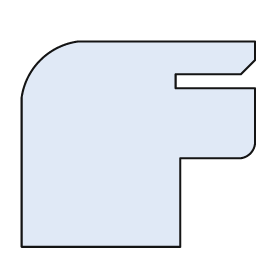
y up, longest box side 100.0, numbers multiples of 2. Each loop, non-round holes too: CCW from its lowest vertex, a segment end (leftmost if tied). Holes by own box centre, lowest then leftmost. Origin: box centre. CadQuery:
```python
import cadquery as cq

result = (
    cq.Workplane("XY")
    .moveTo(-50.0, -44.0)
    .lineTo(18.0, -44.0)
    .lineTo(18.0, -6.0)
    .lineTo(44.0, -6.0)
    .threePointArc((48.0, -4.0), (50.0, 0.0))
    .lineTo(50.0, 24.0)
    .lineTo(16.0, 24.0)
    .lineTo(16.0, 30.0)
    .lineTo(44.0, 30.0)
    .lineTo(50.0, 36.0)
    .lineTo(50.0, 44.0)
    .lineTo(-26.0, 44.0)
    .threePointArc((-42.0, 36.0), (-50.0, 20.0))
    .close()
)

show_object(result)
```